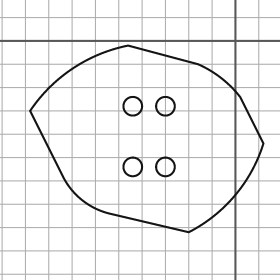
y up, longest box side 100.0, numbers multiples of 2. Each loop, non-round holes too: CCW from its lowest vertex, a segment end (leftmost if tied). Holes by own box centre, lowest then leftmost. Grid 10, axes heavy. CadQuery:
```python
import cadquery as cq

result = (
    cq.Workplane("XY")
    .moveTo(-20.0, -82.0)
    .threePointArc((0.0, -66.0), (12.0, -44.0))
    .lineTo(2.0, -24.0)
    .threePointArc((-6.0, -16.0), (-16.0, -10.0))
    .lineTo(-46.0, -2.0)
    .threePointArc((-70.0, -12.0), (-88.0, -30.0))
    .lineTo(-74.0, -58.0)
    .threePointArc((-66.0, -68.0), (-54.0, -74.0))
    .close()
    .moveTo(-44.0, -54.0)
    .circle(4.0)
    .moveTo(-30.0, -54.0)
    .circle(4.0)
    .moveTo(-44.0, -28.0)
    .circle(4.0)
    .moveTo(-30.0, -28.0)
    .circle(4.0)
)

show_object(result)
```